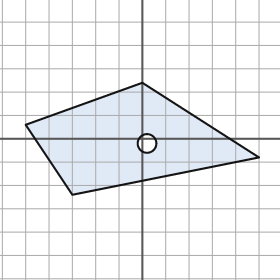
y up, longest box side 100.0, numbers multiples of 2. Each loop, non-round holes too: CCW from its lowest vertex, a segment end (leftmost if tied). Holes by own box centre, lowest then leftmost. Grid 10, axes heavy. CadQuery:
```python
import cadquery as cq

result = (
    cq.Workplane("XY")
    .moveTo(-30.0, -24.0)
    .lineTo(50.0, -8.0)
    .lineTo(0.0, 24.0)
    .lineTo(-50.0, 6.0)
    .close()
    .moveTo(2.0, -2.0)
    .circle(4.0)
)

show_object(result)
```